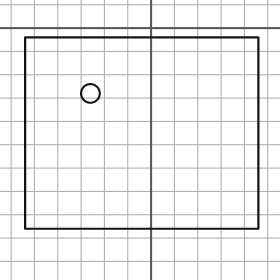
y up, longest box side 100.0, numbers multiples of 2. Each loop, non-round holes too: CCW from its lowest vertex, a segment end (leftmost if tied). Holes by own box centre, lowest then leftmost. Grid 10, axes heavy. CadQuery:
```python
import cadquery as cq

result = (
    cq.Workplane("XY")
    .moveTo(-54.0, -86.0)
    .lineTo(46.0, -86.0)
    .lineTo(46.0, -4.0)
    .lineTo(-54.0, -4.0)
    .close()
    .moveTo(-26.0, -28.0)
    .circle(4.0)
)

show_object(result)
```